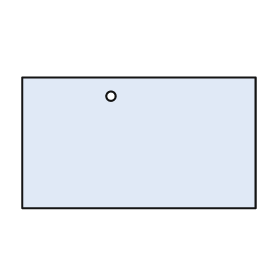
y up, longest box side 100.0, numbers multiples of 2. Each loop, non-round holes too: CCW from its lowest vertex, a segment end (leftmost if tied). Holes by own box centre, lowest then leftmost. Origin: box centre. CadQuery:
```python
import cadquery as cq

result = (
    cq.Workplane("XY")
    .moveTo(-50.0, -28.0)
    .lineTo(50.0, -28.0)
    .lineTo(50.0, 28.0)
    .lineTo(-50.0, 28.0)
    .close()
    .moveTo(-12.0, 20.0)
    .circle(2.0)
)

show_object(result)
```